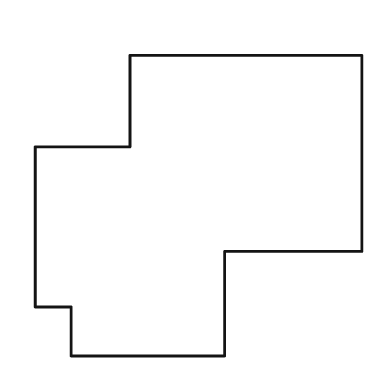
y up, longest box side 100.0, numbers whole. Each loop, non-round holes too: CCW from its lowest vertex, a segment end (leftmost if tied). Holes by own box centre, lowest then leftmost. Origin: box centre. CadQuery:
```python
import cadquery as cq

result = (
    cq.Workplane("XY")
    .moveTo(-39.0, -46.0)
    .lineTo(8.0, -46.0)
    .lineTo(8.0, -14.0)
    .lineTo(50.0, -14.0)
    .lineTo(50.0, 46.0)
    .lineTo(-21.0, 46.0)
    .lineTo(-21.0, 18.0)
    .lineTo(-50.0, 18.0)
    .lineTo(-50.0, -31.0)
    .lineTo(-39.0, -31.0)
    .close()
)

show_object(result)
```